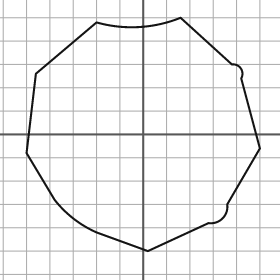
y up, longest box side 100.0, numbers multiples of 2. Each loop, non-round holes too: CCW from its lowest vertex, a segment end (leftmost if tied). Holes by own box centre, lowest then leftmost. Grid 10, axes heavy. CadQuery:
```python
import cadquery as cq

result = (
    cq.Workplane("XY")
    .moveTo(2.0, -50.0)
    .lineTo(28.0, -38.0)
    .threePointArc((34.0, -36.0), (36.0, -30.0))
    .lineTo(50.0, -6.0)
    .lineTo(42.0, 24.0)
    .threePointArc((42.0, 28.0), (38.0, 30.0))
    .lineTo(16.0, 50.0)
    .threePointArc((-2.0, 46.0), (-20.0, 48.0))
    .lineTo(-46.0, 26.0)
    .lineTo(-50.0, -8.0)
    .lineTo(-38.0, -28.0)
    .threePointArc((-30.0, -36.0), (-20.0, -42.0))
    .close()
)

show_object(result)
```